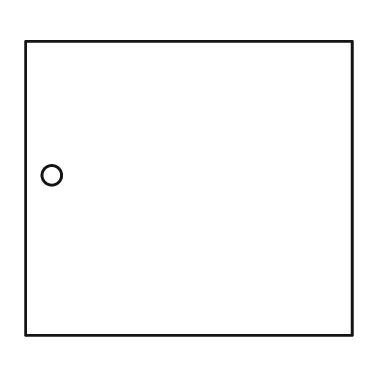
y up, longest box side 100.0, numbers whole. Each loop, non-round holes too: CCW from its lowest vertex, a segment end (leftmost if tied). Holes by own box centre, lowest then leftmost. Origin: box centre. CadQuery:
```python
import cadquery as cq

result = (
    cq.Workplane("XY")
    .moveTo(-50.0, -45.0)
    .lineTo(50.0, -45.0)
    .lineTo(50.0, 45.0)
    .lineTo(-50.0, 45.0)
    .close()
    .moveTo(-42.0, 4.0)
    .circle(3.0)
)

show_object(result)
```